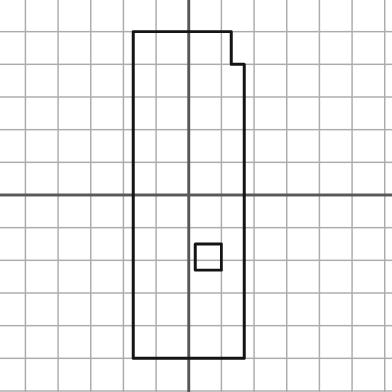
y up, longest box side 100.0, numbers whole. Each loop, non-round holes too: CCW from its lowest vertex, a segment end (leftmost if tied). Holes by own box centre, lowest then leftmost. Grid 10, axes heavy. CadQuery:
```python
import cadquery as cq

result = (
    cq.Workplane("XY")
    .moveTo(-17.0, -50.0)
    .lineTo(17.0, -50.0)
    .lineTo(17.0, 40.0)
    .lineTo(13.0, 40.0)
    .lineTo(13.0, 50.0)
    .lineTo(-17.0, 50.0)
    .close()
    .moveTo(2.0, -23.0)
    .lineTo(10.0, -23.0)
    .lineTo(10.0, -15.0)
    .lineTo(2.0, -15.0)
    .close()
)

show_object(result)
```